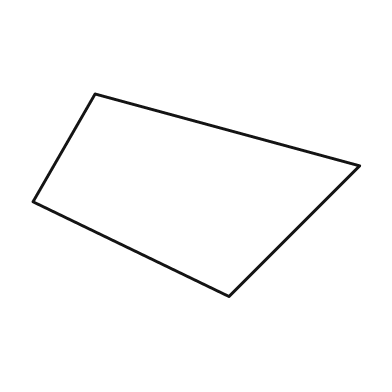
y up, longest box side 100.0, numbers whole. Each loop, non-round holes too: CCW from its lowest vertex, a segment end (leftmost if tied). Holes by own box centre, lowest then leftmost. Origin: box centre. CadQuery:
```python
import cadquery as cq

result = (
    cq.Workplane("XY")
    .moveTo(10.0, -31.0)
    .lineTo(50.0, 9.0)
    .lineTo(-31.0, 31.0)
    .lineTo(-50.0, -2.0)
    .close()
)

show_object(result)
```